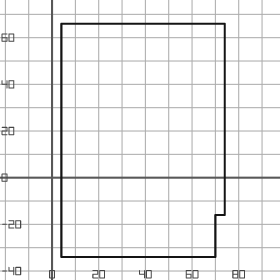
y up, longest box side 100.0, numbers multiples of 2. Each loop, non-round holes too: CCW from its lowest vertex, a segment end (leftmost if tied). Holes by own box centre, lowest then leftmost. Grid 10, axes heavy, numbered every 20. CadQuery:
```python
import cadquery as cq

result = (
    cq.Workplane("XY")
    .moveTo(4.0, -34.0)
    .lineTo(70.0, -34.0)
    .lineTo(70.0, -16.0)
    .lineTo(74.0, -16.0)
    .lineTo(74.0, 66.0)
    .lineTo(4.0, 66.0)
    .close()
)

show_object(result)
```